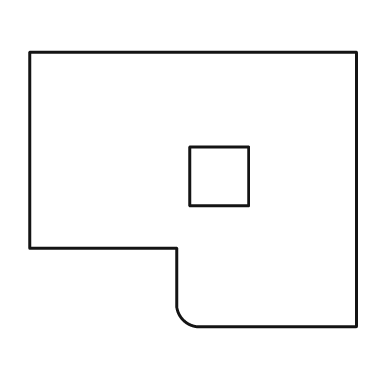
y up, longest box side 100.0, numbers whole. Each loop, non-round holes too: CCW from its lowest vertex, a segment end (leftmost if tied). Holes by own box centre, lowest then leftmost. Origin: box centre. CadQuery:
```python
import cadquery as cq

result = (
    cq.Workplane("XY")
    .moveTo(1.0, -42.0)
    .lineTo(50.0, -42.0)
    .lineTo(50.0, 42.0)
    .lineTo(-50.0, 42.0)
    .lineTo(-50.0, -18.0)
    .lineTo(-5.0, -18.0)
    .lineTo(-5.0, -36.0)
    .threePointArc((-3.0, -40.0), (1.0, -42.0))
    .close()
    .moveTo(-1.0, -5.0)
    .lineTo(17.0, -5.0)
    .lineTo(17.0, 13.0)
    .lineTo(-1.0, 13.0)
    .close()
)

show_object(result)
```